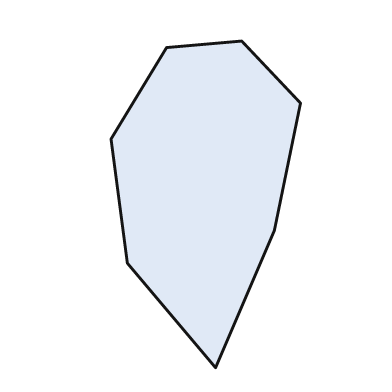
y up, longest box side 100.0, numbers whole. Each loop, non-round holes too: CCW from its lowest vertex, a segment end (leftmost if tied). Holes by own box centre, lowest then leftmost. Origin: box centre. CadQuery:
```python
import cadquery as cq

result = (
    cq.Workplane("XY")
    .moveTo(3.0, -50.0)
    .lineTo(21.0, -8.0)
    .lineTo(29.0, 31.0)
    .lineTo(11.0, 50.0)
    .lineTo(-12.0, 48.0)
    .lineTo(-29.0, 20.0)
    .lineTo(-24.0, -18.0)
    .close()
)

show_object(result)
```